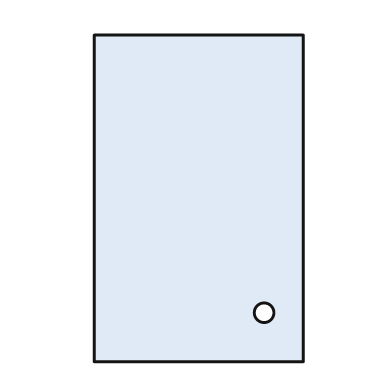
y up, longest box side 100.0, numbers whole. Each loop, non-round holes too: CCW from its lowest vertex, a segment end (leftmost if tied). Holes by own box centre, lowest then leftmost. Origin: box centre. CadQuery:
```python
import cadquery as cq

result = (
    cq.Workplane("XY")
    .moveTo(-32.0, -50.0)
    .lineTo(32.0, -50.0)
    .lineTo(32.0, 50.0)
    .lineTo(-32.0, 50.0)
    .close()
    .moveTo(20.0, -35.0)
    .circle(3.0)
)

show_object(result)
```